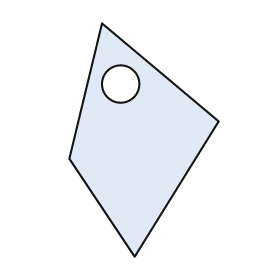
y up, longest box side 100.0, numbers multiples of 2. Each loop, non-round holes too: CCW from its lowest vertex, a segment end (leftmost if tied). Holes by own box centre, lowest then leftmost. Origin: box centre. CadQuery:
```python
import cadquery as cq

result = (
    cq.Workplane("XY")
    .moveTo(-4.0, -50.0)
    .lineTo(32.0, 8.0)
    .lineTo(-18.0, 50.0)
    .lineTo(-32.0, -8.0)
    .close()
    .moveTo(-10.0, 24.0)
    .circle(8.0)
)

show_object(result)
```